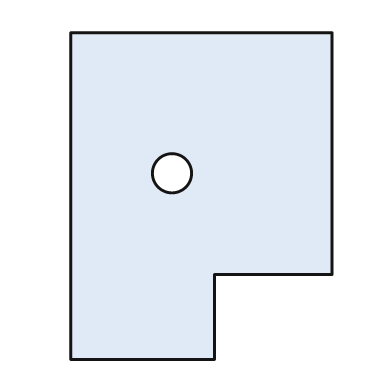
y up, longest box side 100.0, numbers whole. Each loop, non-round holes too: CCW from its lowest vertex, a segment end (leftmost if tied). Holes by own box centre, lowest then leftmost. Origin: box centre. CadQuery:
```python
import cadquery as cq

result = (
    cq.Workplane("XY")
    .moveTo(-40.0, -50.0)
    .lineTo(4.0, -50.0)
    .lineTo(4.0, -24.0)
    .lineTo(40.0, -24.0)
    .lineTo(40.0, 50.0)
    .lineTo(-40.0, 50.0)
    .close()
    .moveTo(-9.0, 7.0)
    .circle(6.0)
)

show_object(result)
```